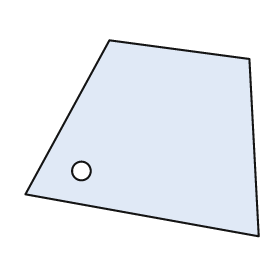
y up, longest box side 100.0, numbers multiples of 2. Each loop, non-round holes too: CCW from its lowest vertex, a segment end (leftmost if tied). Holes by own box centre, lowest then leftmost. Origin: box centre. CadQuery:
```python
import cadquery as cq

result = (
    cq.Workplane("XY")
    .moveTo(50.0, -42.0)
    .lineTo(46.0, 34.0)
    .lineTo(-14.0, 42.0)
    .lineTo(-50.0, -24.0)
    .close()
    .moveTo(-26.0, -14.0)
    .circle(4.0)
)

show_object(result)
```